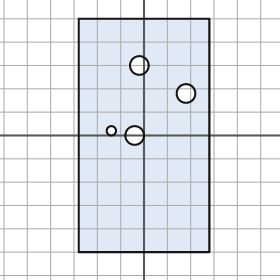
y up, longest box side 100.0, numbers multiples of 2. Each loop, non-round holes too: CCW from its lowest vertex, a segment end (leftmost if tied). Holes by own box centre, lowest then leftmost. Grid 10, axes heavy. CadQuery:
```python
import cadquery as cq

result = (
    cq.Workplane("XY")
    .moveTo(-28.0, -50.0)
    .lineTo(28.0, -50.0)
    .lineTo(28.0, 50.0)
    .lineTo(-28.0, 50.0)
    .close()
    .moveTo(-4.0, 0.0)
    .circle(4.0)
    .moveTo(-14.0, 2.0)
    .circle(2.0)
    .moveTo(18.0, 18.0)
    .circle(4.0)
    .moveTo(-2.0, 30.0)
    .circle(4.0)
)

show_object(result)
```